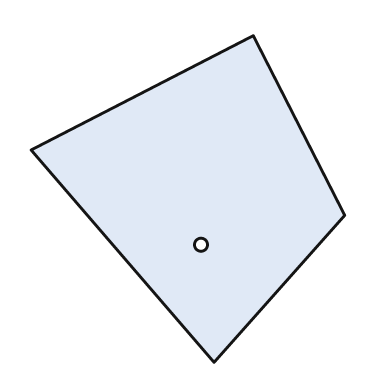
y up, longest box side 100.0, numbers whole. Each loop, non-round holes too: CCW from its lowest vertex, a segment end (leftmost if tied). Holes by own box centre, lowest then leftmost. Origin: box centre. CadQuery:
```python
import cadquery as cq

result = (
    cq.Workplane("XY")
    .moveTo(8.0, -50.0)
    .lineTo(48.0, -5.0)
    .lineTo(20.0, 50.0)
    .lineTo(-48.0, 15.0)
    .close()
    .moveTo(4.0, -14.0)
    .circle(2.0)
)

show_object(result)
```